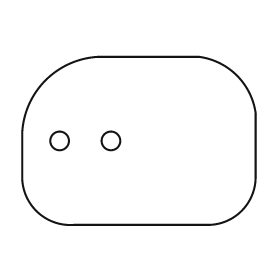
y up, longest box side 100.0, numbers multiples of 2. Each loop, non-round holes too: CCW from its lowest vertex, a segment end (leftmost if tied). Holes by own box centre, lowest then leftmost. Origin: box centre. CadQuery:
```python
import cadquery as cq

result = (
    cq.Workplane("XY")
    .moveTo(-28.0, -36.0)
    .lineTo(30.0, -36.0)
    .threePointArc((44.0, -30.0), (50.0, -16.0))
    .lineTo(50.0, 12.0)
    .threePointArc((42.0, 28.0), (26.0, 36.0))
    .lineTo(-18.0, 36.0)
    .threePointArc((-40.0, 26.0), (-50.0, 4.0))
    .lineTo(-50.0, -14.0)
    .threePointArc((-44.0, -30.0), (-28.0, -36.0))
    .close()
    .moveTo(-34.0, 0.0)
    .circle(4.0)
    .moveTo(-12.0, 0.0)
    .circle(4.0)
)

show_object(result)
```